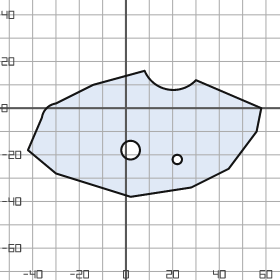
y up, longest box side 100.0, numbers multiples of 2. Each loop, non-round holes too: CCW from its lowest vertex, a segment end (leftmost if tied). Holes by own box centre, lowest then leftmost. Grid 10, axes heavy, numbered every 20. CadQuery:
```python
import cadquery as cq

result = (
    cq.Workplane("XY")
    .moveTo(2.0, -38.0)
    .lineTo(28.0, -34.0)
    .lineTo(44.0, -26.0)
    .lineTo(56.0, -10.0)
    .lineTo(58.0, 0.0)
    .lineTo(30.0, 12.0)
    .threePointArc((18.0, 8.0), (8.0, 16.0))
    .lineTo(-14.0, 10.0)
    .lineTo(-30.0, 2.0)
    .threePointArc((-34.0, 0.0), (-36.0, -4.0))
    .lineTo(-42.0, -18.0)
    .lineTo(-30.0, -28.0)
    .close()
    .moveTo(22.0, -22.0)
    .circle(2.0)
    .moveTo(2.0, -18.0)
    .circle(4.0)
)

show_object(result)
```